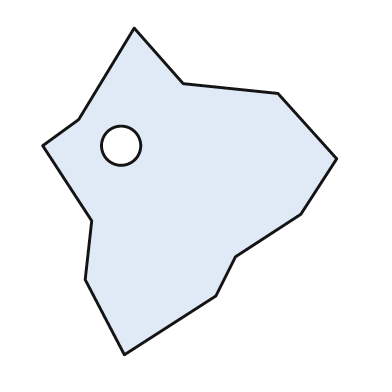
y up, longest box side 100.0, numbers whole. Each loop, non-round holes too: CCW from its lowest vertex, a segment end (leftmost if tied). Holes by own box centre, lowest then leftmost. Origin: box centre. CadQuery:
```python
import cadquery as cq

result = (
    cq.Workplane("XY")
    .moveTo(-20.0, -50.0)
    .lineTo(8.0, -32.0)
    .lineTo(14.0, -20.0)
    .lineTo(34.0, -7.0)
    .lineTo(45.0, 10.0)
    .lineTo(27.0, 30.0)
    .lineTo(-2.0, 33.0)
    .lineTo(-17.0, 50.0)
    .lineTo(-34.0, 22.0)
    .lineTo(-45.0, 14.0)
    .lineTo(-30.0, -9.0)
    .lineTo(-32.0, -27.0)
    .close()
    .moveTo(-21.0, 14.0)
    .circle(6.0)
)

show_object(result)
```